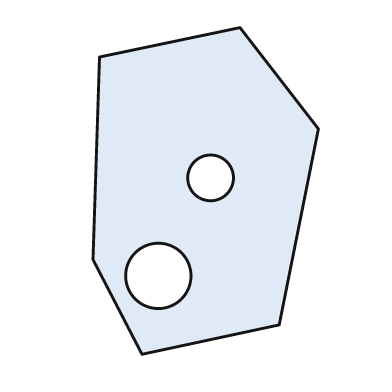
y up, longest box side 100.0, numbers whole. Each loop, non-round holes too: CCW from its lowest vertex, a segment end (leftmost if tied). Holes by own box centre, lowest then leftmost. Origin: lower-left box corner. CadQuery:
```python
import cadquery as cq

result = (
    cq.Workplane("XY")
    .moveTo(15.0, 0.0)
    .lineTo(57.0, 9.0)
    .lineTo(69.0, 69.0)
    .lineTo(45.0, 100.0)
    .lineTo(2.0, 91.0)
    .lineTo(0.0, 29.0)
    .close()
    .moveTo(20.0, 24.0)
    .circle(10.0)
    .moveTo(36.0, 54.0)
    .circle(7.0)
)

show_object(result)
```